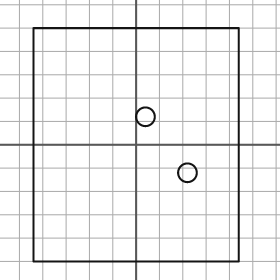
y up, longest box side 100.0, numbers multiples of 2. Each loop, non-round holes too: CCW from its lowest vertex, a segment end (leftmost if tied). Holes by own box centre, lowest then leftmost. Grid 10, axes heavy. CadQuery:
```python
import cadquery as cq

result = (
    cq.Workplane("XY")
    .moveTo(-44.0, -50.0)
    .lineTo(44.0, -50.0)
    .lineTo(44.0, 50.0)
    .lineTo(-44.0, 50.0)
    .close()
    .moveTo(22.0, -12.0)
    .circle(4.0)
    .moveTo(4.0, 12.0)
    .circle(4.0)
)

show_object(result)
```